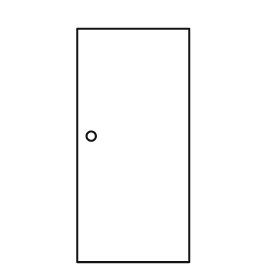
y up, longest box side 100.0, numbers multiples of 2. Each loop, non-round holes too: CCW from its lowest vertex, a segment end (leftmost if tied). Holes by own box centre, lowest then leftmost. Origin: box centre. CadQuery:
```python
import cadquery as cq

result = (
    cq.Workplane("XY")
    .moveTo(-24.0, -50.0)
    .lineTo(24.0, -50.0)
    .lineTo(24.0, 50.0)
    .lineTo(-24.0, 50.0)
    .close()
    .moveTo(-18.0, 4.0)
    .circle(2.0)
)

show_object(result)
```